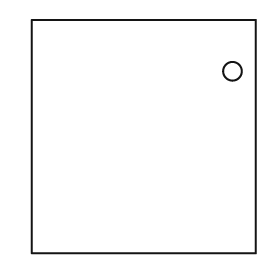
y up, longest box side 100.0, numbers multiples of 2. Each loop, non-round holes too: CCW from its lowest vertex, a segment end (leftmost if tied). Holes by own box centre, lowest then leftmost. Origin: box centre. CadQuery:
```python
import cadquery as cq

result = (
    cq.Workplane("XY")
    .moveTo(-48.0, -50.0)
    .lineTo(48.0, -50.0)
    .lineTo(48.0, 50.0)
    .lineTo(-48.0, 50.0)
    .close()
    .moveTo(38.0, 28.0)
    .circle(4.0)
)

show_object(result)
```